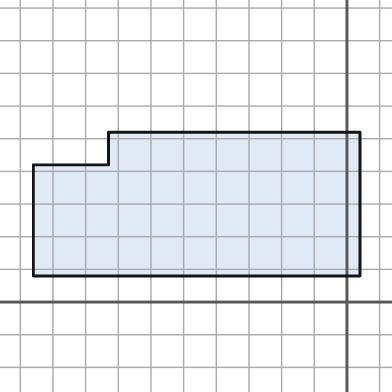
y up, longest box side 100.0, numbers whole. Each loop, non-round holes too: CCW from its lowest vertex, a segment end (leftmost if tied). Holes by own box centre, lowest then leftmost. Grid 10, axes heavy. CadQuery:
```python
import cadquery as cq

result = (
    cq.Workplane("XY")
    .moveTo(-96.0, 8.0)
    .lineTo(4.0, 8.0)
    .lineTo(4.0, 52.0)
    .lineTo(-73.0, 52.0)
    .lineTo(-73.0, 42.0)
    .lineTo(-96.0, 42.0)
    .close()
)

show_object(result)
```